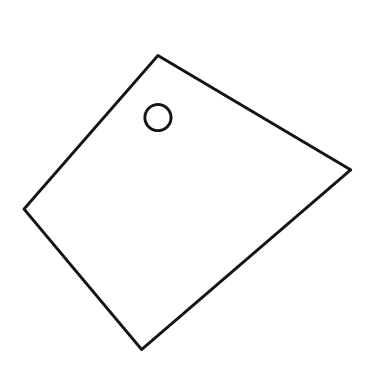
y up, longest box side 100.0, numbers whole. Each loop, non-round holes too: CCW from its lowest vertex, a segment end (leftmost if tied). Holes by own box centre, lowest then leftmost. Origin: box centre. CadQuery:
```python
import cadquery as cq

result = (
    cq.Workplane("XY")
    .moveTo(-14.0, -45.0)
    .lineTo(50.0, 10.0)
    .lineTo(-9.0, 45.0)
    .lineTo(-50.0, -2.0)
    .close()
    .moveTo(-9.0, 26.0)
    .circle(4.0)
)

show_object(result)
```